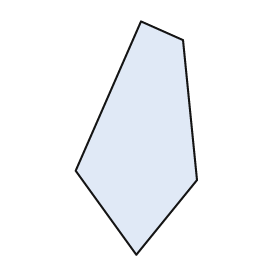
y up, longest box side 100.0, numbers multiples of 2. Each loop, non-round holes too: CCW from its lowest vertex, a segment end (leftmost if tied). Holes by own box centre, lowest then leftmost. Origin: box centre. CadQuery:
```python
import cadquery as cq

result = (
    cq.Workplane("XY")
    .moveTo(0.0, -50.0)
    .lineTo(26.0, -18.0)
    .lineTo(20.0, 42.0)
    .lineTo(2.0, 50.0)
    .lineTo(-26.0, -14.0)
    .close()
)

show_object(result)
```